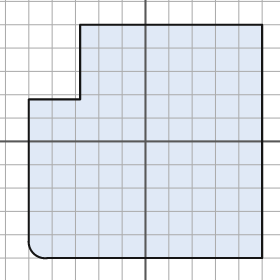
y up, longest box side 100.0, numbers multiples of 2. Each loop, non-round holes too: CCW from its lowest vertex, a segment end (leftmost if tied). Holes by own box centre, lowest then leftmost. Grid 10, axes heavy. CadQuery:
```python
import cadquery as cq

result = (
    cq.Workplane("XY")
    .moveTo(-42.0, -50.0)
    .lineTo(50.0, -50.0)
    .lineTo(50.0, 50.0)
    .lineTo(-28.0, 50.0)
    .lineTo(-28.0, 18.0)
    .lineTo(-50.0, 18.0)
    .lineTo(-50.0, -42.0)
    .threePointArc((-48.0, -48.0), (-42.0, -50.0))
    .close()
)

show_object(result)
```